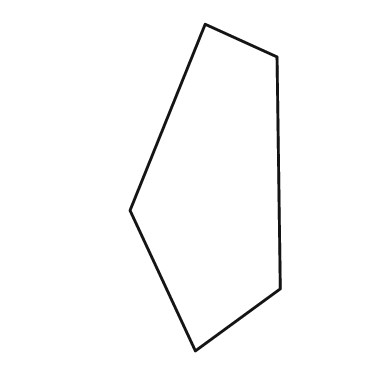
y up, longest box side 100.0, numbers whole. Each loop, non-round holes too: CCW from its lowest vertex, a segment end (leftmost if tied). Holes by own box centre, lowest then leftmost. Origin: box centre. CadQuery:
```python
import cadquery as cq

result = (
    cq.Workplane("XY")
    .moveTo(-3.0, -50.0)
    .lineTo(23.0, -31.0)
    .lineTo(22.0, 40.0)
    .lineTo(0.0, 50.0)
    .lineTo(-23.0, -7.0)
    .close()
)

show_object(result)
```